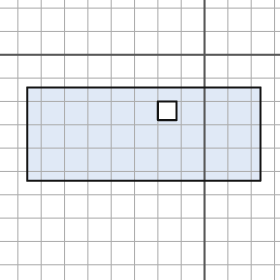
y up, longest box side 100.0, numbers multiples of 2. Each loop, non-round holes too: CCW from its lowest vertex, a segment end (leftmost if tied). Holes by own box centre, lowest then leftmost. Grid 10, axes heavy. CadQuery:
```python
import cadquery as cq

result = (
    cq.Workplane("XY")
    .moveTo(-76.0, -54.0)
    .lineTo(24.0, -54.0)
    .lineTo(24.0, -14.0)
    .lineTo(-76.0, -14.0)
    .close()
    .moveTo(-20.0, -28.0)
    .lineTo(-12.0, -28.0)
    .lineTo(-12.0, -20.0)
    .lineTo(-20.0, -20.0)
    .close()
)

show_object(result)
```